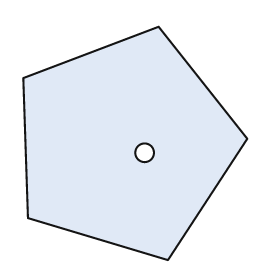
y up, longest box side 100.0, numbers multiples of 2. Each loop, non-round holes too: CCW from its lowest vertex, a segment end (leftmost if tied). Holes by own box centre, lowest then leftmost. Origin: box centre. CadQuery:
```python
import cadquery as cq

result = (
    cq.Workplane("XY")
    .moveTo(14.0, -50.0)
    .lineTo(48.0, 2.0)
    .lineTo(10.0, 50.0)
    .lineTo(-48.0, 28.0)
    .lineTo(-46.0, -32.0)
    .close()
    .moveTo(4.0, -4.0)
    .circle(4.0)
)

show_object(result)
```